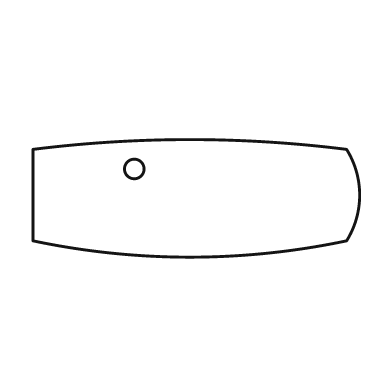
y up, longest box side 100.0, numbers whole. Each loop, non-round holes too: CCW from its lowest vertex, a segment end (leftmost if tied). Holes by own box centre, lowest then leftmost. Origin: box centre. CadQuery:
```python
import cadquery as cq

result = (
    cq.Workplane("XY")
    .moveTo(-50.0, -13.0)
    .threePointArc((-2.0, -18.0), (46.0, -13.0))
    .threePointArc((50.0, 1.0), (46.0, 15.0))
    .threePointArc((-2.0, 18.0), (-50.0, 15.0))
    .close()
    .moveTo(-19.0, 9.0)
    .circle(3.0)
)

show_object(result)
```